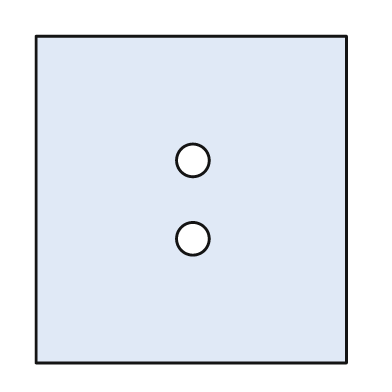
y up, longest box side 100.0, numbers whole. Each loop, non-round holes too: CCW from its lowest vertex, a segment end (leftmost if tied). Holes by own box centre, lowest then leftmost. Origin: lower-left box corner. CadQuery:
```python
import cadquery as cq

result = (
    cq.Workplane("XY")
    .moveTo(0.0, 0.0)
    .lineTo(95.0, 0.0)
    .lineTo(95.0, 100.0)
    .lineTo(0.0, 100.0)
    .close()
    .moveTo(48.0, 38.0)
    .circle(5.0)
    .moveTo(48.0, 62.0)
    .circle(5.0)
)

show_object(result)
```